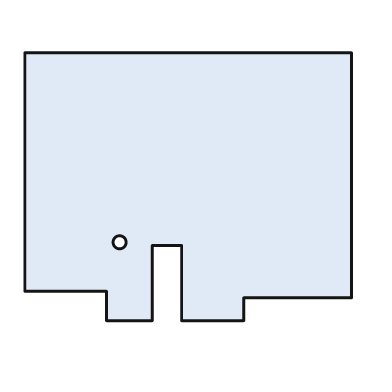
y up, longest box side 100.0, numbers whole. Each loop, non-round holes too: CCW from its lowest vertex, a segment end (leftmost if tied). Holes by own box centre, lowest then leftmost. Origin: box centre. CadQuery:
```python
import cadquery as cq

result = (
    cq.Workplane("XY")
    .moveTo(-25.0, -41.0)
    .lineTo(-11.0, -41.0)
    .lineTo(-11.0, -18.0)
    .lineTo(-2.0, -18.0)
    .lineTo(-2.0, -41.0)
    .lineTo(17.0, -41.0)
    .lineTo(17.0, -34.0)
    .lineTo(50.0, -34.0)
    .lineTo(50.0, 41.0)
    .lineTo(-50.0, 41.0)
    .lineTo(-50.0, -32.0)
    .lineTo(-25.0, -32.0)
    .close()
    .moveTo(-21.0, -17.0)
    .circle(2.0)
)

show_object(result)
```